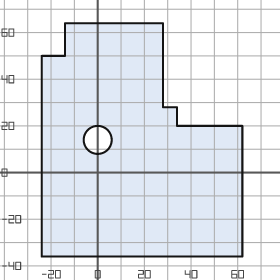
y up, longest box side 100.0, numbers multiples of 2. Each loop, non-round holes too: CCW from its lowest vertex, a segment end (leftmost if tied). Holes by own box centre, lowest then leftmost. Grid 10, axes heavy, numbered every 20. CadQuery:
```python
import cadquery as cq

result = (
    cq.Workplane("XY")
    .moveTo(-24.0, -36.0)
    .lineTo(62.0, -36.0)
    .lineTo(62.0, 20.0)
    .lineTo(34.0, 20.0)
    .lineTo(34.0, 28.0)
    .lineTo(28.0, 28.0)
    .lineTo(28.0, 64.0)
    .lineTo(-14.0, 64.0)
    .lineTo(-14.0, 50.0)
    .lineTo(-24.0, 50.0)
    .close()
    .moveTo(0.0, 14.0)
    .circle(6.0)
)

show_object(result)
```